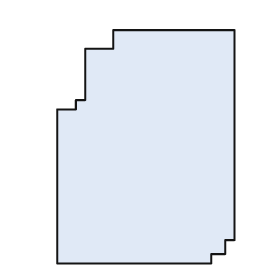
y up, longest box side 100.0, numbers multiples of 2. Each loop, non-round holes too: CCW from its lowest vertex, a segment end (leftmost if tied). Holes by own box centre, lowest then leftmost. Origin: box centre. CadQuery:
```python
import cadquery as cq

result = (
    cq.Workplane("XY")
    .moveTo(-38.0, -50.0)
    .lineTo(28.0, -50.0)
    .lineTo(28.0, -46.0)
    .lineTo(34.0, -46.0)
    .lineTo(34.0, -40.0)
    .lineTo(38.0, -40.0)
    .lineTo(38.0, 50.0)
    .lineTo(-14.0, 50.0)
    .lineTo(-14.0, 42.0)
    .lineTo(-26.0, 42.0)
    .lineTo(-26.0, 20.0)
    .lineTo(-30.0, 20.0)
    .lineTo(-30.0, 16.0)
    .lineTo(-38.0, 16.0)
    .close()
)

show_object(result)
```